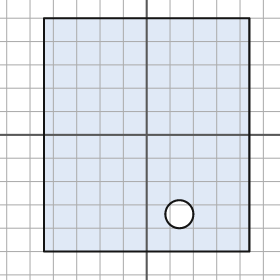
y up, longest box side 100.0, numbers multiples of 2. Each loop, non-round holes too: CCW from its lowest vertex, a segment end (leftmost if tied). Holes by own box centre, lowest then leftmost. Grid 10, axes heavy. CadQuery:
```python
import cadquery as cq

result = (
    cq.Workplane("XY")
    .moveTo(-44.0, -50.0)
    .lineTo(44.0, -50.0)
    .lineTo(44.0, 50.0)
    .lineTo(-44.0, 50.0)
    .close()
    .moveTo(14.0, -34.0)
    .circle(6.0)
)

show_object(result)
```